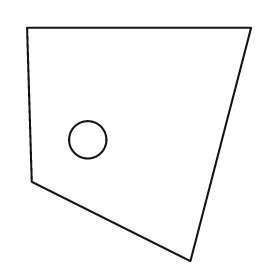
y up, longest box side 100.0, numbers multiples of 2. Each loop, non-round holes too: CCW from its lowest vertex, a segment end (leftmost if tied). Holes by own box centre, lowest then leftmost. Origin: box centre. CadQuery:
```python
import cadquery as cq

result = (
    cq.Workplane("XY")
    .moveTo(22.0, -50.0)
    .lineTo(48.0, 50.0)
    .lineTo(-48.0, 50.0)
    .lineTo(-46.0, -16.0)
    .close()
    .moveTo(-22.0, 2.0)
    .circle(8.0)
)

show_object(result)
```